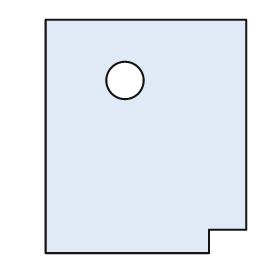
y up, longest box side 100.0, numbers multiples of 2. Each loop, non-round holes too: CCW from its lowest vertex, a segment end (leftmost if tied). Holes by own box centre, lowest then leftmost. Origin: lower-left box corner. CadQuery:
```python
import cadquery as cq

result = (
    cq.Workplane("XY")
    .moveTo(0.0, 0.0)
    .lineTo(70.0, 0.0)
    .lineTo(70.0, 10.0)
    .lineTo(86.0, 10.0)
    .lineTo(86.0, 100.0)
    .lineTo(0.0, 100.0)
    .close()
    .moveTo(34.0, 74.0)
    .circle(8.0)
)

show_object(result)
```